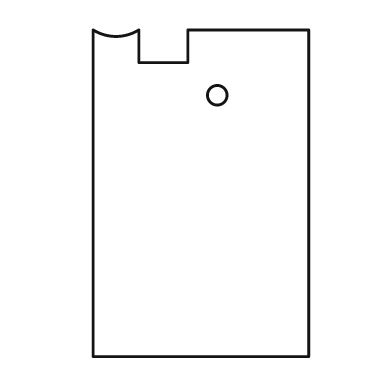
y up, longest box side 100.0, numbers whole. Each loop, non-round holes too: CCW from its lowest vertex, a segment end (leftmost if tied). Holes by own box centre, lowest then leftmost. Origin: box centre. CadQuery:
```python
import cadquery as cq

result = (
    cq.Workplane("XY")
    .moveTo(-33.0, -50.0)
    .lineTo(33.0, -50.0)
    .lineTo(33.0, 50.0)
    .lineTo(-4.0, 50.0)
    .lineTo(-4.0, 40.0)
    .lineTo(-19.0, 40.0)
    .lineTo(-19.0, 50.0)
    .threePointArc((-26.0, 48.0), (-33.0, 50.0))
    .close()
    .moveTo(5.0, 30.0)
    .circle(3.0)
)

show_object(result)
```